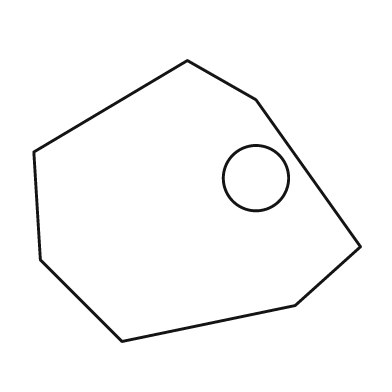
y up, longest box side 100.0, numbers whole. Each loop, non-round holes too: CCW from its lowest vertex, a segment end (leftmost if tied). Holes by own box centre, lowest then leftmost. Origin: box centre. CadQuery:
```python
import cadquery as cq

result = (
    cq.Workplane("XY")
    .moveTo(-23.0, -43.0)
    .lineTo(30.0, -32.0)
    .lineTo(50.0, -14.0)
    .lineTo(18.0, 31.0)
    .lineTo(-3.0, 43.0)
    .lineTo(-50.0, 15.0)
    .lineTo(-48.0, -18.0)
    .close()
    .moveTo(18.0, 7.0)
    .circle(10.0)
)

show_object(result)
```